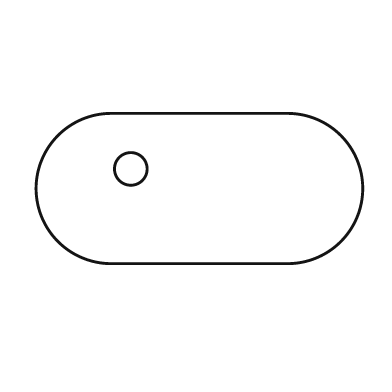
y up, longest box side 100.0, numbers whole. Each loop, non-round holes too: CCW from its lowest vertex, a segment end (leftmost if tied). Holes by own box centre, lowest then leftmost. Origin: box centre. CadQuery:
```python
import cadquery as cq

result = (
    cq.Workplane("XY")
    .moveTo(-27.0, -23.0)
    .lineTo(27.0, -23.0)
    .threePointArc((50.0, 0.0), (27.0, 23.0))
    .lineTo(-27.0, 23.0)
    .threePointArc((-50.0, 0.0), (-27.0, -23.0))
    .close()
    .moveTo(-21.0, 6.0)
    .circle(5.0)
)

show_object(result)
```